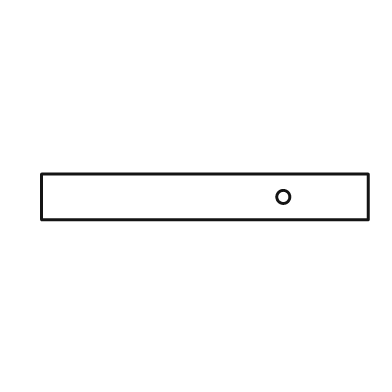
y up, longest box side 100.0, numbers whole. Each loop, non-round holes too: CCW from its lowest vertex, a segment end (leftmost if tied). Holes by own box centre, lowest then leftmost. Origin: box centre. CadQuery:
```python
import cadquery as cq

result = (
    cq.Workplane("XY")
    .moveTo(-50.0, -7.0)
    .lineTo(50.0, -7.0)
    .lineTo(50.0, 7.0)
    .lineTo(-50.0, 7.0)
    .close()
    .moveTo(24.0, 0.0)
    .circle(2.0)
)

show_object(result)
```